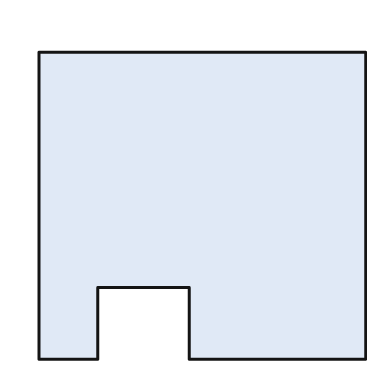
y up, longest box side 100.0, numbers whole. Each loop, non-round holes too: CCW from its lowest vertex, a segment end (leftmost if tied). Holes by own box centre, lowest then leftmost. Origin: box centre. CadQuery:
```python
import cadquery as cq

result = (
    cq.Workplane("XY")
    .moveTo(-50.0, -47.0)
    .lineTo(-32.0, -47.0)
    .lineTo(-32.0, -25.0)
    .lineTo(-4.0, -25.0)
    .lineTo(-4.0, -47.0)
    .lineTo(50.0, -47.0)
    .lineTo(50.0, 47.0)
    .lineTo(-50.0, 47.0)
    .close()
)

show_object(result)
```